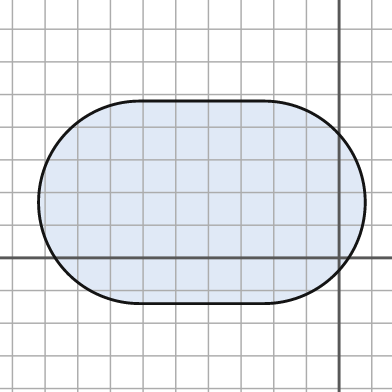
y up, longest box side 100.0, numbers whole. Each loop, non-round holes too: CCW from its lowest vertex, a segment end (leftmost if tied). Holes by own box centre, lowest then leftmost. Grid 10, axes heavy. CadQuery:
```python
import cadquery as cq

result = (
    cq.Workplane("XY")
    .moveTo(-61.0, -14.0)
    .lineTo(-23.0, -14.0)
    .threePointArc((8.0, 17.0), (-23.0, 48.0))
    .lineTo(-61.0, 48.0)
    .threePointArc((-92.0, 17.0), (-61.0, -14.0))
    .close()
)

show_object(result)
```